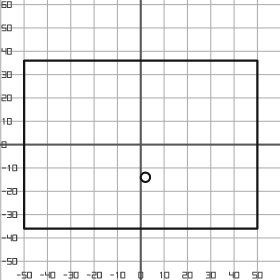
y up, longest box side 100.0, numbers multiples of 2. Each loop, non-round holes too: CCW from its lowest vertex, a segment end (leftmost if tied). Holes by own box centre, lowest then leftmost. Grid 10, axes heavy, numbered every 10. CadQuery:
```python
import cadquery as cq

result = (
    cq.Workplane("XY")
    .moveTo(-50.0, -36.0)
    .lineTo(50.0, -36.0)
    .lineTo(50.0, 36.0)
    .lineTo(-50.0, 36.0)
    .close()
    .moveTo(2.0, -14.0)
    .circle(2.0)
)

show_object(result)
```